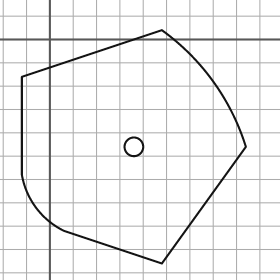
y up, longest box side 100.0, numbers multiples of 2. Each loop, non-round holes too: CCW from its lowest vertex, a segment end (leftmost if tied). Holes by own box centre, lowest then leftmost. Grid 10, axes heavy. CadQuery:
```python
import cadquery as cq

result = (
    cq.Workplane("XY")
    .moveTo(48.0, -96.0)
    .lineTo(84.0, -46.0)
    .threePointArc((70.0, -18.0), (48.0, 4.0))
    .lineTo(-12.0, -16.0)
    .lineTo(-12.0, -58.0)
    .threePointArc((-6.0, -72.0), (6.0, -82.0))
    .close()
    .moveTo(36.0, -46.0)
    .circle(4.0)
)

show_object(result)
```